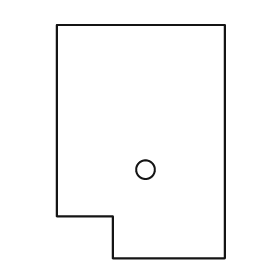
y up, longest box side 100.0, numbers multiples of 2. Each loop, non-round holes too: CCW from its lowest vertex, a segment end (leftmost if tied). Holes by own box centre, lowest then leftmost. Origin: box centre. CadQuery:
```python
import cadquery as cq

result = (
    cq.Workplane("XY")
    .moveTo(-12.0, -50.0)
    .lineTo(36.0, -50.0)
    .lineTo(36.0, 50.0)
    .lineTo(-36.0, 50.0)
    .lineTo(-36.0, -32.0)
    .lineTo(-12.0, -32.0)
    .close()
    .moveTo(2.0, -12.0)
    .circle(4.0)
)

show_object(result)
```